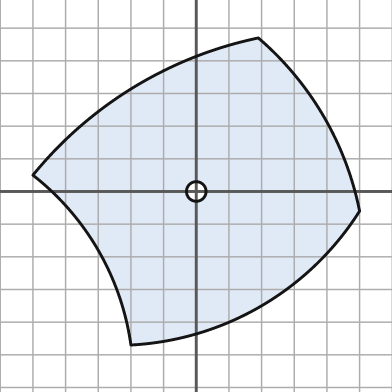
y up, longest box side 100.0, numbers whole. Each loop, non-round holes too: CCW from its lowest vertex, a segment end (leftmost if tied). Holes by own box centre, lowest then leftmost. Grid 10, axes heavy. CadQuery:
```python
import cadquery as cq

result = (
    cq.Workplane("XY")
    .moveTo(-20.0, -47.0)
    .threePointArc((20.0, -35.0), (50.0, -6.0))
    .threePointArc((39.0, 23.0), (19.0, 47.0))
    .threePointArc((-19.0, 32.0), (-50.0, 5.0))
    .threePointArc((-30.0, -18.0), (-20.0, -47.0))
    .close()
    .moveTo(0.0, 0.0)
    .circle(3.0)
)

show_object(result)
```